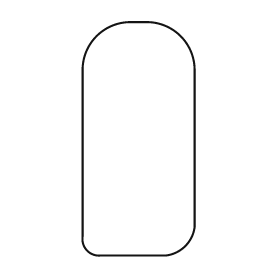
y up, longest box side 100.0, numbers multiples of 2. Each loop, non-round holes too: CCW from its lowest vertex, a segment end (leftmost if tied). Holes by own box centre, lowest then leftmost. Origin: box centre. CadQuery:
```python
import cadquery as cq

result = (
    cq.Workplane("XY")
    .moveTo(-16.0, -50.0)
    .lineTo(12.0, -50.0)
    .threePointArc((20.0, -46.0), (24.0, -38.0))
    .lineTo(24.0, 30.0)
    .threePointArc((18.0, 44.0), (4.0, 50.0))
    .lineTo(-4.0, 50.0)
    .threePointArc((-18.0, 44.0), (-24.0, 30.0))
    .lineTo(-24.0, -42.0)
    .threePointArc((-22.0, -48.0), (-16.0, -50.0))
    .close()
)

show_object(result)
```